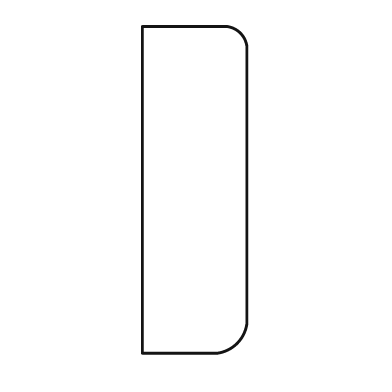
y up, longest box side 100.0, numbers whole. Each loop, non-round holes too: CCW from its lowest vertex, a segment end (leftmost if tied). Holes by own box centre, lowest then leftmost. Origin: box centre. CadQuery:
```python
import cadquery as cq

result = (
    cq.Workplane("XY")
    .moveTo(-16.0, -50.0)
    .lineTo(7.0, -50.0)
    .threePointArc((13.0, -47.0), (16.0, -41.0))
    .lineTo(16.0, 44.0)
    .threePointArc((14.0, 48.0), (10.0, 50.0))
    .lineTo(-16.0, 50.0)
    .close()
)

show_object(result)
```